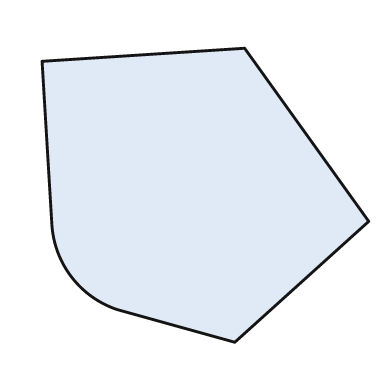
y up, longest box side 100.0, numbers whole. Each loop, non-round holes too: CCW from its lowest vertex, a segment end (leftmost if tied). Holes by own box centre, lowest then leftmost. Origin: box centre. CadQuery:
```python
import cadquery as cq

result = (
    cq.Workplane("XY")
    .moveTo(9.0, -45.0)
    .lineTo(50.0, -8.0)
    .lineTo(12.0, 45.0)
    .lineTo(-50.0, 41.0)
    .lineTo(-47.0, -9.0)
    .threePointArc((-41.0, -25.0), (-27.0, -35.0))
    .close()
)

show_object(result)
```